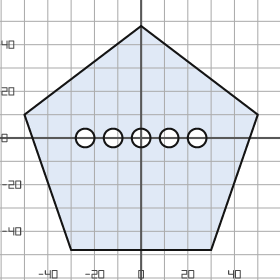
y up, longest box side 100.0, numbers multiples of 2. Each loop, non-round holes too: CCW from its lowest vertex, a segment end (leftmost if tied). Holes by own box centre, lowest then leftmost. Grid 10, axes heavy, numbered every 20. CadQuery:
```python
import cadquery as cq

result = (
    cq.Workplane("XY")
    .moveTo(-30.0, -48.0)
    .lineTo(30.0, -48.0)
    .lineTo(50.0, 10.0)
    .lineTo(0.0, 48.0)
    .lineTo(-50.0, 10.0)
    .close()
    .moveTo(-24.0, 0.0)
    .circle(4.0)
    .moveTo(-12.0, 0.0)
    .circle(4.0)
    .moveTo(0.0, 0.0)
    .circle(4.0)
    .moveTo(12.0, 0.0)
    .circle(4.0)
    .moveTo(24.0, 0.0)
    .circle(4.0)
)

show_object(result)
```